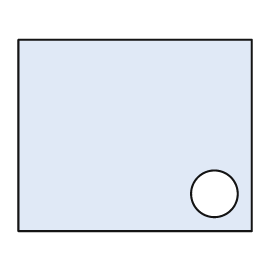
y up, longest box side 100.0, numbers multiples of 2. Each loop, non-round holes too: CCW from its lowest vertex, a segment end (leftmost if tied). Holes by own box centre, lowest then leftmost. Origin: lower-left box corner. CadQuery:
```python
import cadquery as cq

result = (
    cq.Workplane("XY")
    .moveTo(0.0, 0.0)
    .lineTo(100.0, 0.0)
    .lineTo(100.0, 82.0)
    .lineTo(0.0, 82.0)
    .close()
    .moveTo(84.0, 16.0)
    .circle(10.0)
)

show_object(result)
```